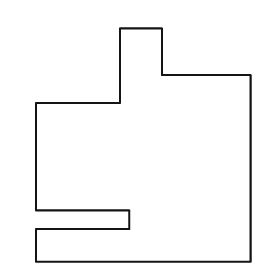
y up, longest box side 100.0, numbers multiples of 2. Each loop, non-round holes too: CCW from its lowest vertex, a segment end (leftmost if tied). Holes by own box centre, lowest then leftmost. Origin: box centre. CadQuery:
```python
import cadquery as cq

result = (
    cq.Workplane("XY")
    .moveTo(-46.0, -50.0)
    .lineTo(46.0, -50.0)
    .lineTo(46.0, 30.0)
    .lineTo(8.0, 30.0)
    .lineTo(8.0, 50.0)
    .lineTo(-10.0, 50.0)
    .lineTo(-10.0, 18.0)
    .lineTo(-46.0, 18.0)
    .lineTo(-46.0, -28.0)
    .lineTo(-6.0, -28.0)
    .lineTo(-6.0, -36.0)
    .lineTo(-46.0, -36.0)
    .close()
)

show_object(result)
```